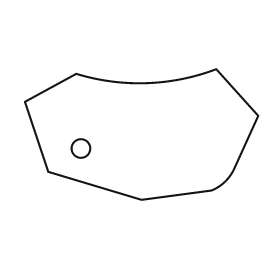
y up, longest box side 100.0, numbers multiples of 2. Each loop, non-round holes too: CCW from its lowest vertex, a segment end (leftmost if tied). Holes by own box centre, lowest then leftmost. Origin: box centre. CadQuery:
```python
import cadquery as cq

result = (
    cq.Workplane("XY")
    .moveTo(0.0, -28.0)
    .lineTo(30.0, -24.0)
    .threePointArc((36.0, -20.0), (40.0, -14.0))
    .lineTo(50.0, 8.0)
    .lineTo(32.0, 28.0)
    .threePointArc((2.0, 22.0), (-28.0, 26.0))
    .lineTo(-50.0, 14.0)
    .lineTo(-40.0, -16.0)
    .close()
    .moveTo(-26.0, -6.0)
    .circle(4.0)
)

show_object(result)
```